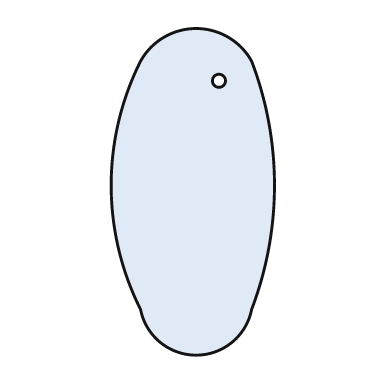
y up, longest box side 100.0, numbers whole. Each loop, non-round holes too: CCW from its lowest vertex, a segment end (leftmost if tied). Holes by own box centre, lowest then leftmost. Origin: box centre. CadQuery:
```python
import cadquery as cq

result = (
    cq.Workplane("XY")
    .moveTo(-16.0, -36.0)
    .threePointArc((1.0, -50.0), (18.0, -36.0))
    .threePointArc((25.0, 2.0), (18.0, 40.0))
    .threePointArc((1.0, 50.0), (-16.0, 40.0))
    .threePointArc((-25.0, 2.0), (-16.0, -36.0))
    .close()
    .moveTo(8.0, 34.0)
    .circle(2.0)
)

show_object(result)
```